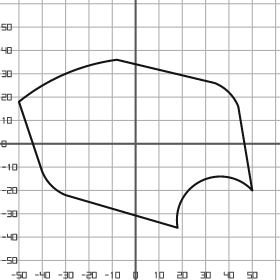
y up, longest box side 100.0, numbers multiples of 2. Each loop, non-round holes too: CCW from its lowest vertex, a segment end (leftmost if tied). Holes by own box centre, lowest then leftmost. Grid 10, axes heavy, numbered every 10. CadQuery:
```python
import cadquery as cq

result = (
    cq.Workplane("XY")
    .moveTo(18.0, -36.0)
    .threePointArc((28.0, -16.0), (50.0, -20.0))
    .lineTo(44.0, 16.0)
    .threePointArc((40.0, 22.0), (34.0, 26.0))
    .lineTo(-8.0, 36.0)
    .threePointArc((-30.0, 30.0), (-50.0, 18.0))
    .lineTo(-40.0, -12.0)
    .threePointArc((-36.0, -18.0), (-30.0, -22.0))
    .close()
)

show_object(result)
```